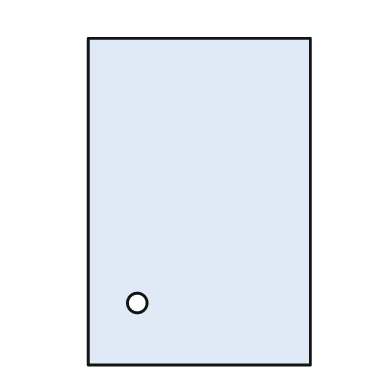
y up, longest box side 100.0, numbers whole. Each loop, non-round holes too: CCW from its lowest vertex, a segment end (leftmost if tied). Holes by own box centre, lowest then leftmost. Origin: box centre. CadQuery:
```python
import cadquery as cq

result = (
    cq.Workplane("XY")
    .moveTo(-34.0, -50.0)
    .lineTo(34.0, -50.0)
    .lineTo(34.0, 50.0)
    .lineTo(-34.0, 50.0)
    .close()
    .moveTo(-19.0, -31.0)
    .circle(3.0)
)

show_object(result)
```